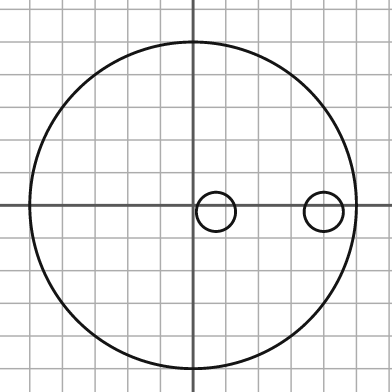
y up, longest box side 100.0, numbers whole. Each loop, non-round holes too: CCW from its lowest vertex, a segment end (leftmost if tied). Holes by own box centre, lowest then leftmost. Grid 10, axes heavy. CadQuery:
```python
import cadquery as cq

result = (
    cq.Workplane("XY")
    .moveTo(0.0, 0.0)
    .circle(50.0)
    .moveTo(7.0, -2.0)
    .circle(6.0)
    .moveTo(40.0, -2.0)
    .circle(6.0)
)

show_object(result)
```